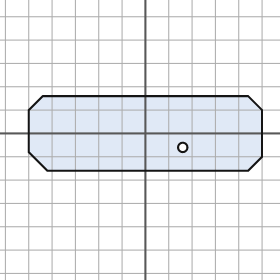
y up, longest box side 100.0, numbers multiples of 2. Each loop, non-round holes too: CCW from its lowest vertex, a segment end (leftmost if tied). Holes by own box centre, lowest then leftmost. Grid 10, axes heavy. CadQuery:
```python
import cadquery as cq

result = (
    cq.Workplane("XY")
    .moveTo(-42.0, -16.0)
    .lineTo(44.0, -16.0)
    .lineTo(50.0, -10.0)
    .lineTo(50.0, 10.0)
    .lineTo(44.0, 16.0)
    .lineTo(-44.0, 16.0)
    .lineTo(-50.0, 10.0)
    .lineTo(-50.0, -8.0)
    .close()
    .moveTo(16.0, -6.0)
    .circle(2.0)
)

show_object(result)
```